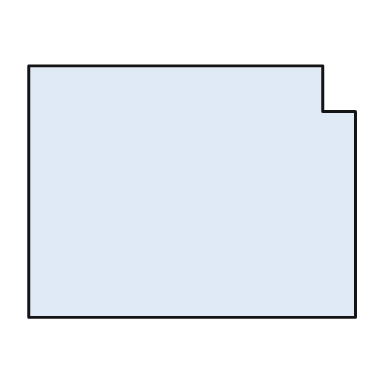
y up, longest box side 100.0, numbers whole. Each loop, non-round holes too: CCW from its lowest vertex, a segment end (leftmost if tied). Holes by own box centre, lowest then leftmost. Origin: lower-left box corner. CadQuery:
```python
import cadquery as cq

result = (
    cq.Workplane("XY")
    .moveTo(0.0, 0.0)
    .lineTo(100.0, 0.0)
    .lineTo(100.0, 63.0)
    .lineTo(90.0, 63.0)
    .lineTo(90.0, 77.0)
    .lineTo(0.0, 77.0)
    .close()
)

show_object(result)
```